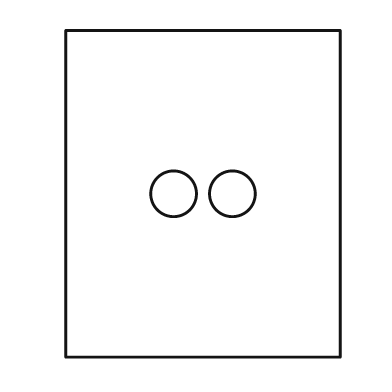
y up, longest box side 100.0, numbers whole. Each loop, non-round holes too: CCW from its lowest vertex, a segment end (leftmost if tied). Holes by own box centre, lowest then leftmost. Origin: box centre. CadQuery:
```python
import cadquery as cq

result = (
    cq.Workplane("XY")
    .moveTo(-42.0, -50.0)
    .lineTo(42.0, -50.0)
    .lineTo(42.0, 50.0)
    .lineTo(-42.0, 50.0)
    .close()
    .moveTo(-9.0, 0.0)
    .circle(7.0)
    .moveTo(9.0, 0.0)
    .circle(7.0)
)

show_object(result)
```